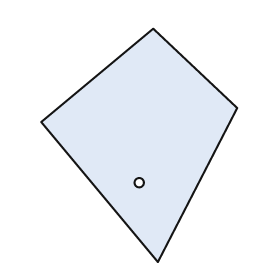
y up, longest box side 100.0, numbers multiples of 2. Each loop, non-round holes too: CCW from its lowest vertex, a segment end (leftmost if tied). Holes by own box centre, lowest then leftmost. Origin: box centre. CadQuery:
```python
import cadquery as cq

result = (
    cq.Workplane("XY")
    .moveTo(8.0, -50.0)
    .lineTo(42.0, 16.0)
    .lineTo(6.0, 50.0)
    .lineTo(-42.0, 10.0)
    .close()
    .moveTo(0.0, -16.0)
    .circle(2.0)
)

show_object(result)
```